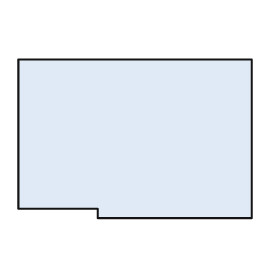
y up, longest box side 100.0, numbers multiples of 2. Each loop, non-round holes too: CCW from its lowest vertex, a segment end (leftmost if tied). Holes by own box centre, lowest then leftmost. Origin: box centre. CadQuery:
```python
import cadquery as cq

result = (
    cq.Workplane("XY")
    .moveTo(-16.0, -34.0)
    .lineTo(50.0, -34.0)
    .lineTo(50.0, 34.0)
    .lineTo(-50.0, 34.0)
    .lineTo(-50.0, -30.0)
    .lineTo(-16.0, -30.0)
    .close()
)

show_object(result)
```